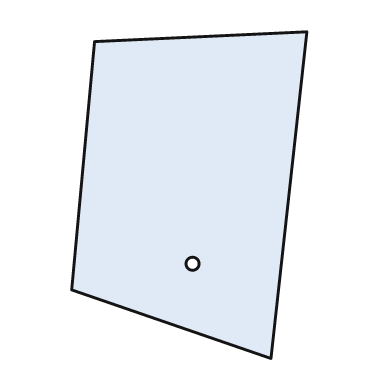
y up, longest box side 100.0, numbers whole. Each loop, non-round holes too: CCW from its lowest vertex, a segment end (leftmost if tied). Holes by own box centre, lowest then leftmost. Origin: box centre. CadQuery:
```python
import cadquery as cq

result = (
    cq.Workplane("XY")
    .moveTo(25.0, -50.0)
    .lineTo(36.0, 50.0)
    .lineTo(-29.0, 47.0)
    .lineTo(-36.0, -29.0)
    .close()
    .moveTo(1.0, -21.0)
    .circle(2.0)
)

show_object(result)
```